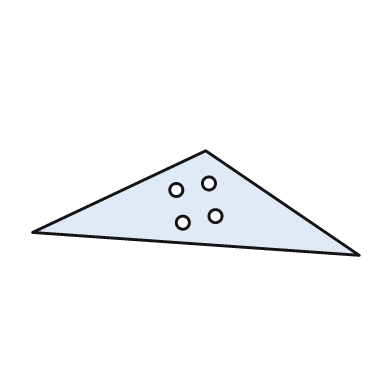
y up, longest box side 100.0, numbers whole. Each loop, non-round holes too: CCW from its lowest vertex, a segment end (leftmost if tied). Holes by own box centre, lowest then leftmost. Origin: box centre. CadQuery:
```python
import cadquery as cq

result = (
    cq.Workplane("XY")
    .moveTo(50.0, -16.0)
    .lineTo(3.0, 16.0)
    .lineTo(-50.0, -9.0)
    .close()
    .moveTo(-4.0, -6.0)
    .circle(2.0)
    .moveTo(6.0, -4.0)
    .circle(2.0)
    .moveTo(-6.0, 4.0)
    .circle(2.0)
    .moveTo(4.0, 6.0)
    .circle(2.0)
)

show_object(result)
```